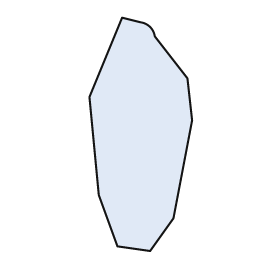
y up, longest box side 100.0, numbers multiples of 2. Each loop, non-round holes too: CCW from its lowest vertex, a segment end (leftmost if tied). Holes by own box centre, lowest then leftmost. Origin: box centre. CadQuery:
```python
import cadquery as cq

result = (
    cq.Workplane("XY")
    .moveTo(4.0, -50.0)
    .lineTo(14.0, -36.0)
    .lineTo(22.0, 6.0)
    .lineTo(20.0, 24.0)
    .lineTo(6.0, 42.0)
    .threePointArc((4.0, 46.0), (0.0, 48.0))
    .lineTo(-8.0, 50.0)
    .lineTo(-22.0, 16.0)
    .lineTo(-18.0, -26.0)
    .lineTo(-10.0, -48.0)
    .close()
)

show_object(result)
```